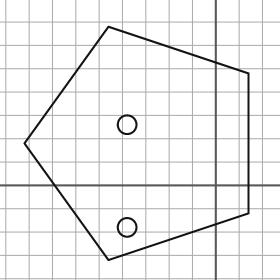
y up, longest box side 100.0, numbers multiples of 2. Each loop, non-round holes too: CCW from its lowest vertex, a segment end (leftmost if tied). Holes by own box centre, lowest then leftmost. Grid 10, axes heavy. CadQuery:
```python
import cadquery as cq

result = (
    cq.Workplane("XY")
    .moveTo(-46.0, -32.0)
    .lineTo(14.0, -12.0)
    .lineTo(14.0, 48.0)
    .lineTo(-46.0, 68.0)
    .lineTo(-82.0, 18.0)
    .close()
    .moveTo(-38.0, -18.0)
    .circle(4.0)
    .moveTo(-38.0, 26.0)
    .circle(4.0)
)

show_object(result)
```